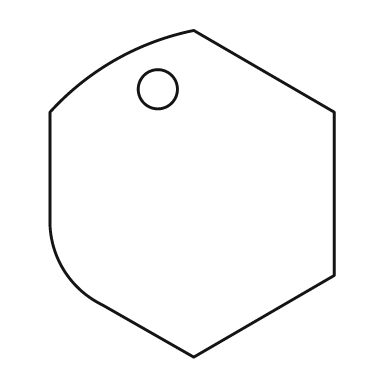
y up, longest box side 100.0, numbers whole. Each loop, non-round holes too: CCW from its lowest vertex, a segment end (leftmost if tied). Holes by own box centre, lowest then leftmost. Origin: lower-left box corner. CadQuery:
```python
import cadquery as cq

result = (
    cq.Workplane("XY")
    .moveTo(44.0, 0.0)
    .lineTo(87.0, 25.0)
    .lineTo(87.0, 75.0)
    .lineTo(44.0, 100.0)
    .threePointArc((20.0, 91.0), (0.0, 75.0))
    .lineTo(0.0, 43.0)
    .threePointArc((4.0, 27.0), (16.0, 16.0))
    .close()
    .moveTo(33.0, 82.0)
    .circle(6.0)
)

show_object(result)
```